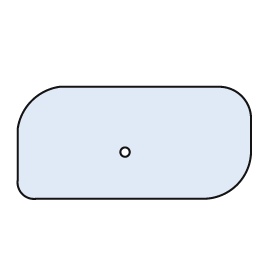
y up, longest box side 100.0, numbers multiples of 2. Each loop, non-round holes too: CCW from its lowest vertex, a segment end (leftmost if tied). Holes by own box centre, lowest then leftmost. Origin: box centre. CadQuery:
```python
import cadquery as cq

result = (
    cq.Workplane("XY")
    .moveTo(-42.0, -24.0)
    .lineTo(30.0, -24.0)
    .threePointArc((44.0, -18.0), (50.0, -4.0))
    .lineTo(50.0, 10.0)
    .threePointArc((46.0, 20.0), (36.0, 24.0))
    .lineTo(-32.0, 24.0)
    .threePointArc((-44.0, 18.0), (-50.0, 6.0))
    .lineTo(-50.0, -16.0)
    .threePointArc((-48.0, -22.0), (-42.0, -24.0))
    .close()
    .moveTo(-4.0, -4.0)
    .circle(2.0)
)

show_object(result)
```